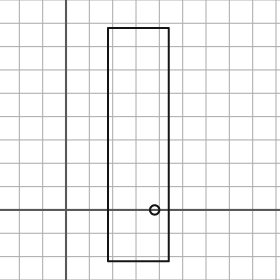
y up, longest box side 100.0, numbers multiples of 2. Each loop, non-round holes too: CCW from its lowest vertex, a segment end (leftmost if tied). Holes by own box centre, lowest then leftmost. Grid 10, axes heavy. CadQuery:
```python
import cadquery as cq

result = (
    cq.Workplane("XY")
    .moveTo(18.0, -22.0)
    .lineTo(44.0, -22.0)
    .lineTo(44.0, 78.0)
    .lineTo(18.0, 78.0)
    .close()
    .moveTo(38.0, 0.0)
    .circle(2.0)
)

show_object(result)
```